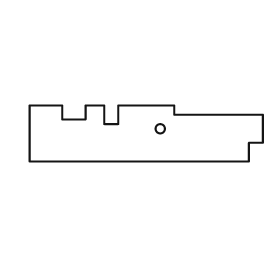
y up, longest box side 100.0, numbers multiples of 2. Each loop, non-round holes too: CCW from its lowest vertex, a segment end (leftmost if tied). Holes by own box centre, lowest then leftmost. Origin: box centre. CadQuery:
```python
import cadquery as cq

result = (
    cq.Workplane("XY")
    .moveTo(-50.0, -12.0)
    .lineTo(44.0, -12.0)
    .lineTo(44.0, -4.0)
    .lineTo(50.0, -4.0)
    .lineTo(50.0, 8.0)
    .lineTo(12.0, 8.0)
    .lineTo(12.0, 12.0)
    .lineTo(-12.0, 12.0)
    .lineTo(-12.0, 4.0)
    .lineTo(-18.0, 4.0)
    .lineTo(-18.0, 12.0)
    .lineTo(-26.0, 12.0)
    .lineTo(-26.0, 6.0)
    .lineTo(-36.0, 6.0)
    .lineTo(-36.0, 12.0)
    .lineTo(-50.0, 12.0)
    .close()
    .moveTo(6.0, 2.0)
    .circle(2.0)
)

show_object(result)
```